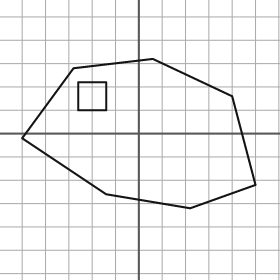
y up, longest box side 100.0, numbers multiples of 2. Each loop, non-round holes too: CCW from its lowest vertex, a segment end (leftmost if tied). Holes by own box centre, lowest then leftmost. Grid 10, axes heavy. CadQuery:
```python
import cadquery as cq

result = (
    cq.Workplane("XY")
    .moveTo(22.0, -32.0)
    .lineTo(50.0, -22.0)
    .lineTo(40.0, 16.0)
    .lineTo(6.0, 32.0)
    .lineTo(-28.0, 28.0)
    .lineTo(-50.0, -2.0)
    .lineTo(-14.0, -26.0)
    .close()
    .moveTo(-26.0, 10.0)
    .lineTo(-14.0, 10.0)
    .lineTo(-14.0, 22.0)
    .lineTo(-26.0, 22.0)
    .close()
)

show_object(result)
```